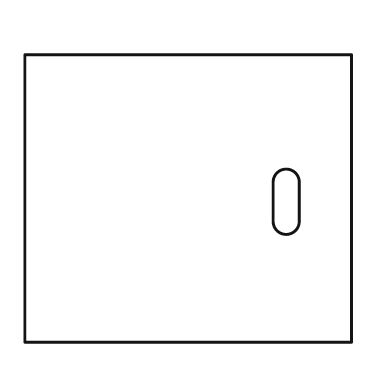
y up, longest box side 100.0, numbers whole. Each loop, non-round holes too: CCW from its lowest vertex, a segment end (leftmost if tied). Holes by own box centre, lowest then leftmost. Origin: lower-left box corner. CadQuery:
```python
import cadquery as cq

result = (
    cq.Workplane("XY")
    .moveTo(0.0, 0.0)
    .lineTo(100.0, 0.0)
    .lineTo(100.0, 88.0)
    .lineTo(0.0, 88.0)
    .close()
    .moveTo(76.0, 37.0)
    .threePointArc((80.0, 33.0), (84.0, 37.0))
    .lineTo(84.0, 49.0)
    .threePointArc((80.0, 53.0), (76.0, 49.0))
    .close()
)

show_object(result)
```